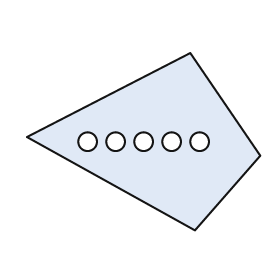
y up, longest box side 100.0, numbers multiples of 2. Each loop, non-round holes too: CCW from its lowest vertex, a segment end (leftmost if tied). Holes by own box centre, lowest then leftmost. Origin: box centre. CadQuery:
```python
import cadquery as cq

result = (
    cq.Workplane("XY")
    .moveTo(22.0, -38.0)
    .lineTo(50.0, -6.0)
    .lineTo(20.0, 38.0)
    .lineTo(-50.0, 2.0)
    .close()
    .moveTo(-24.0, 0.0)
    .circle(4.0)
    .moveTo(-12.0, 0.0)
    .circle(4.0)
    .moveTo(0.0, 0.0)
    .circle(4.0)
    .moveTo(12.0, 0.0)
    .circle(4.0)
    .moveTo(24.0, 0.0)
    .circle(4.0)
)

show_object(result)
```